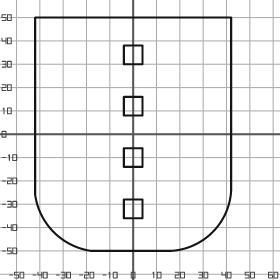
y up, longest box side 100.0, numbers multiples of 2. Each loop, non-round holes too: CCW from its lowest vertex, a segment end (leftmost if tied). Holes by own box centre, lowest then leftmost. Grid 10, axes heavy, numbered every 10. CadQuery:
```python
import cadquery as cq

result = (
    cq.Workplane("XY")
    .moveTo(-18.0, -50.0)
    .lineTo(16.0, -50.0)
    .threePointArc((34.0, -42.0), (42.0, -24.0))
    .lineTo(42.0, 50.0)
    .lineTo(-42.0, 50.0)
    .lineTo(-42.0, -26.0)
    .threePointArc((-34.0, -42.0), (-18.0, -50.0))
    .close()
    .moveTo(-4.0, -36.0)
    .lineTo(4.0, -36.0)
    .lineTo(4.0, -28.0)
    .lineTo(-4.0, -28.0)
    .close()
    .moveTo(-4.0, -14.0)
    .lineTo(4.0, -14.0)
    .lineTo(4.0, -6.0)
    .lineTo(-4.0, -6.0)
    .close()
    .moveTo(-4.0, 8.0)
    .lineTo(4.0, 8.0)
    .lineTo(4.0, 16.0)
    .lineTo(-4.0, 16.0)
    .close()
    .moveTo(-4.0, 30.0)
    .lineTo(4.0, 30.0)
    .lineTo(4.0, 38.0)
    .lineTo(-4.0, 38.0)
    .close()
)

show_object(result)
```